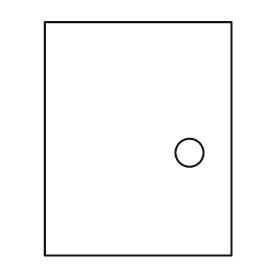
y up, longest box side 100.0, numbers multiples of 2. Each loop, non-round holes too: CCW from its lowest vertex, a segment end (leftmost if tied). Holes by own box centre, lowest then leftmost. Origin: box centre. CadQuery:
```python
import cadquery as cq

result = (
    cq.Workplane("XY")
    .moveTo(-40.0, -50.0)
    .lineTo(40.0, -50.0)
    .lineTo(40.0, 50.0)
    .lineTo(-40.0, 50.0)
    .close()
    .moveTo(22.0, -6.0)
    .circle(6.0)
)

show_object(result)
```